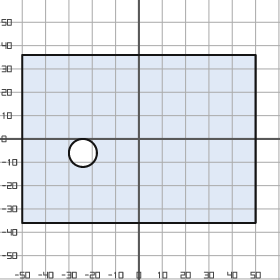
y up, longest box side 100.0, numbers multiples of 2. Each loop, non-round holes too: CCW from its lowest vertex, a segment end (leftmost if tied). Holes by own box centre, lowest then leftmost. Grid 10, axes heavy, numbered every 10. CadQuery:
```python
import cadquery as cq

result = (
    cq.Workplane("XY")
    .moveTo(-50.0, -36.0)
    .lineTo(50.0, -36.0)
    .lineTo(50.0, 36.0)
    .lineTo(-50.0, 36.0)
    .close()
    .moveTo(-24.0, -6.0)
    .circle(6.0)
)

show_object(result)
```